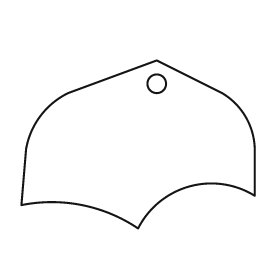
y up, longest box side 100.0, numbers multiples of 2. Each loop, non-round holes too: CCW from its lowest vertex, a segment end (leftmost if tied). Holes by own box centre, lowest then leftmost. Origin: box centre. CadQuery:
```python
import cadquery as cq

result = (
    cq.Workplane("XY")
    .moveTo(0.0, -36.0)
    .threePointArc((22.0, -18.0), (50.0, -22.0))
    .lineTo(50.0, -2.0)
    .threePointArc((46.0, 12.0), (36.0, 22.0))
    .lineTo(8.0, 36.0)
    .lineTo(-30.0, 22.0)
    .threePointArc((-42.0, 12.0), (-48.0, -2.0))
    .lineTo(-50.0, -26.0)
    .threePointArc((-24.0, -26.0), (0.0, -36.0))
    .close()
    .moveTo(8.0, 26.0)
    .circle(4.0)
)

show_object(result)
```